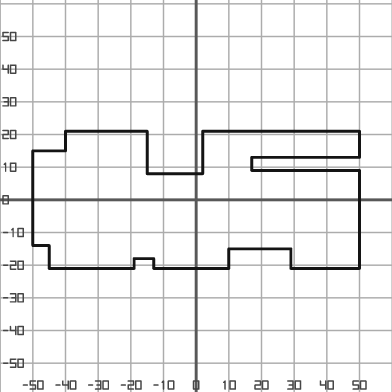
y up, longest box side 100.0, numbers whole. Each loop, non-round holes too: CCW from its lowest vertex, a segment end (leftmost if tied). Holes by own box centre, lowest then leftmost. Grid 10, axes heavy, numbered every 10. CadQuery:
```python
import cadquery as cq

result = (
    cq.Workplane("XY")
    .moveTo(-45.0, -21.0)
    .lineTo(-19.0, -21.0)
    .lineTo(-19.0, -18.0)
    .lineTo(-13.0, -18.0)
    .lineTo(-13.0, -21.0)
    .lineTo(10.0, -21.0)
    .lineTo(10.0, -15.0)
    .lineTo(29.0, -15.0)
    .lineTo(29.0, -21.0)
    .lineTo(50.0, -21.0)
    .lineTo(50.0, 9.0)
    .lineTo(17.0, 9.0)
    .lineTo(17.0, 13.0)
    .lineTo(50.0, 13.0)
    .lineTo(50.0, 21.0)
    .lineTo(2.0, 21.0)
    .lineTo(2.0, 8.0)
    .lineTo(-15.0, 8.0)
    .lineTo(-15.0, 21.0)
    .lineTo(-40.0, 21.0)
    .lineTo(-40.0, 15.0)
    .lineTo(-50.0, 15.0)
    .lineTo(-50.0, -14.0)
    .lineTo(-45.0, -14.0)
    .close()
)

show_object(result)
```